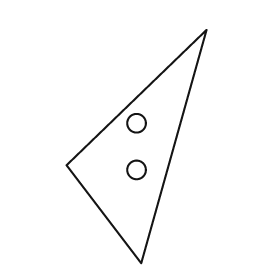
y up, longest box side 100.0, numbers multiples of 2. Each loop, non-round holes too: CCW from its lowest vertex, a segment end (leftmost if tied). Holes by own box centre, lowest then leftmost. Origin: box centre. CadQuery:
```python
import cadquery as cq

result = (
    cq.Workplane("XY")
    .moveTo(2.0, -50.0)
    .lineTo(30.0, 50.0)
    .lineTo(-30.0, -8.0)
    .close()
    .moveTo(0.0, -10.0)
    .circle(4.0)
    .moveTo(0.0, 10.0)
    .circle(4.0)
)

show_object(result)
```